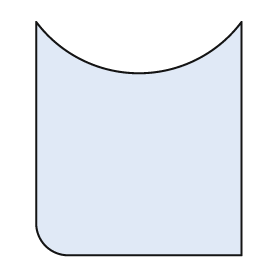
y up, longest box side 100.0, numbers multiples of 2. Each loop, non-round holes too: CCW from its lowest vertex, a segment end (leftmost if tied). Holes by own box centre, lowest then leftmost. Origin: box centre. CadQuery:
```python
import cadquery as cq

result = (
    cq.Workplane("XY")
    .moveTo(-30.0, -50.0)
    .lineTo(44.0, -50.0)
    .lineTo(44.0, 50.0)
    .threePointArc((0.0, 28.0), (-44.0, 50.0))
    .lineTo(-44.0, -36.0)
    .threePointArc((-40.0, -46.0), (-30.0, -50.0))
    .close()
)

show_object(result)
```